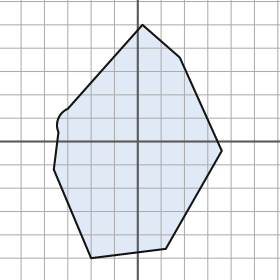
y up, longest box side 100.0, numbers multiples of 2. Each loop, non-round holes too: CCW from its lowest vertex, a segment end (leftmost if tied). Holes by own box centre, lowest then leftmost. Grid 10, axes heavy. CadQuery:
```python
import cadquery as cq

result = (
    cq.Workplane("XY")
    .moveTo(-20.0, -50.0)
    .lineTo(12.0, -46.0)
    .lineTo(36.0, -4.0)
    .lineTo(18.0, 36.0)
    .lineTo(2.0, 50.0)
    .lineTo(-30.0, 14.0)
    .threePointArc((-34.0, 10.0), (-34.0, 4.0))
    .lineTo(-36.0, -12.0)
    .close()
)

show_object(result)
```